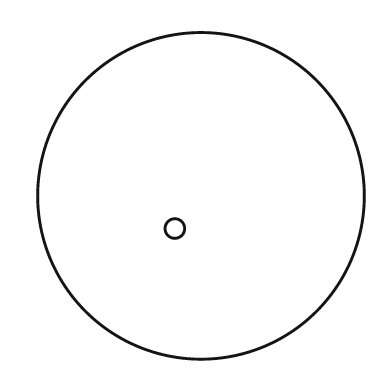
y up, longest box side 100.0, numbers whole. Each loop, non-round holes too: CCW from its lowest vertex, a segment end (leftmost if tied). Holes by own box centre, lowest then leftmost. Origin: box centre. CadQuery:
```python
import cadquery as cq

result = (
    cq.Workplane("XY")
    .moveTo(0.0, 0.0)
    .circle(50.0)
    .moveTo(-8.0, -10.0)
    .circle(3.0)
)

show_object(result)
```